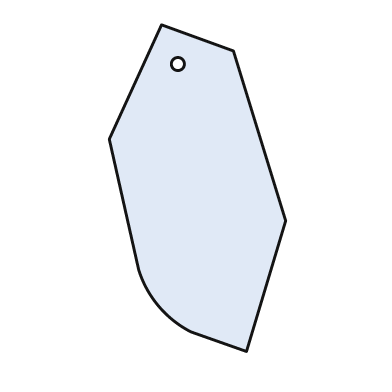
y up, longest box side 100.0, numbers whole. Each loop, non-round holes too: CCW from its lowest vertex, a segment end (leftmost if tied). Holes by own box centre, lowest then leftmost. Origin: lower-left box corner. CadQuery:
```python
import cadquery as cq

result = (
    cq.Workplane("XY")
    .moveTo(42.0, 0.0)
    .lineTo(54.0, 40.0)
    .lineTo(38.0, 92.0)
    .lineTo(16.0, 100.0)
    .lineTo(0.0, 65.0)
    .lineTo(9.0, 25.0)
    .threePointArc((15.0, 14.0), (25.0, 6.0))
    .close()
    .moveTo(21.0, 88.0)
    .circle(2.0)
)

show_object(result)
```